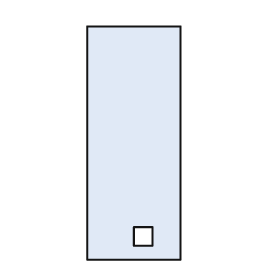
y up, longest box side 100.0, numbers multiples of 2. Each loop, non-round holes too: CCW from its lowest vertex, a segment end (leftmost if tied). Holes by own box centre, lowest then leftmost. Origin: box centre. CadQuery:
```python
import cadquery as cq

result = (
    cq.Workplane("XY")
    .moveTo(-20.0, -50.0)
    .lineTo(20.0, -50.0)
    .lineTo(20.0, 50.0)
    .lineTo(-20.0, 50.0)
    .close()
    .moveTo(0.0, -44.0)
    .lineTo(8.0, -44.0)
    .lineTo(8.0, -36.0)
    .lineTo(0.0, -36.0)
    .close()
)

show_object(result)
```